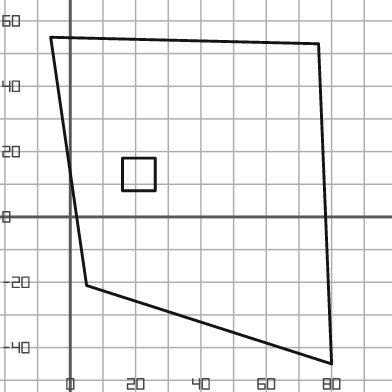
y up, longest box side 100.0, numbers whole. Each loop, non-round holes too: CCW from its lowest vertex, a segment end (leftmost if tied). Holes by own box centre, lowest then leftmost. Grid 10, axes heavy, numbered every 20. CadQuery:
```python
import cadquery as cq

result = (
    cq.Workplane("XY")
    .moveTo(80.0, -45.0)
    .lineTo(76.0, 53.0)
    .lineTo(-6.0, 55.0)
    .lineTo(5.0, -21.0)
    .close()
    .moveTo(16.0, 8.0)
    .lineTo(26.0, 8.0)
    .lineTo(26.0, 18.0)
    .lineTo(16.0, 18.0)
    .close()
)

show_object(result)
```